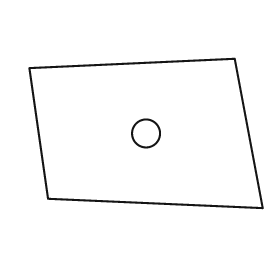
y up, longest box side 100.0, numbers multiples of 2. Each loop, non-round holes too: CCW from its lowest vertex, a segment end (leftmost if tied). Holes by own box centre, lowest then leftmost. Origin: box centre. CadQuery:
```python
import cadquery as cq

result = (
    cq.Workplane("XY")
    .moveTo(50.0, -32.0)
    .lineTo(38.0, 32.0)
    .lineTo(-50.0, 28.0)
    .lineTo(-42.0, -28.0)
    .close()
    .moveTo(0.0, 0.0)
    .circle(6.0)
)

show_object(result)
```